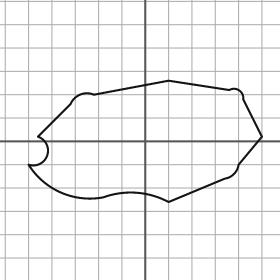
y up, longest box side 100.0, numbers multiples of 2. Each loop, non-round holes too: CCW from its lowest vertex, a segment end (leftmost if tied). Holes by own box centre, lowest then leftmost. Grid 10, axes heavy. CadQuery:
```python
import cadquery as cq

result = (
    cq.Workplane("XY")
    .moveTo(10.0, -26.0)
    .lineTo(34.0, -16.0)
    .threePointArc((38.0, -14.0), (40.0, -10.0))
    .lineTo(50.0, 2.0)
    .lineTo(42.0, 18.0)
    .threePointArc((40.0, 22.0), (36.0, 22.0))
    .lineTo(10.0, 26.0)
    .lineTo(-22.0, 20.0)
    .threePointArc((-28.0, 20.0), (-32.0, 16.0))
    .lineTo(-46.0, 2.0)
    .threePointArc((-42.0, -6.0), (-50.0, -10.0))
    .threePointArc((-36.0, -22.0), (-18.0, -24.0))
    .threePointArc((-4.0, -22.0), (10.0, -26.0))
    .close()
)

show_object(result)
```